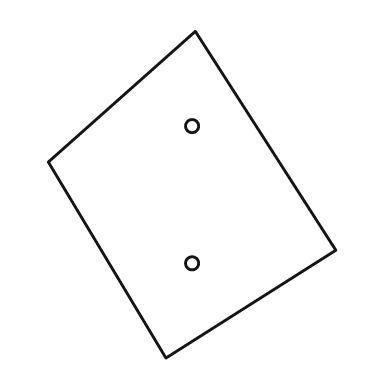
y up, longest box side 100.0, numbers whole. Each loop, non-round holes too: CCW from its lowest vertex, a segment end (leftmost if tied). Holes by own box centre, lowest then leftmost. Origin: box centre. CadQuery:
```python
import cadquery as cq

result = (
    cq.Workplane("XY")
    .moveTo(-8.0, -50.0)
    .lineTo(44.0, -17.0)
    .lineTo(1.0, 50.0)
    .lineTo(-44.0, 10.0)
    .close()
    .moveTo(0.0, -21.0)
    .circle(2.0)
    .moveTo(0.0, 21.0)
    .circle(2.0)
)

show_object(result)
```